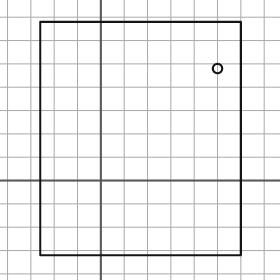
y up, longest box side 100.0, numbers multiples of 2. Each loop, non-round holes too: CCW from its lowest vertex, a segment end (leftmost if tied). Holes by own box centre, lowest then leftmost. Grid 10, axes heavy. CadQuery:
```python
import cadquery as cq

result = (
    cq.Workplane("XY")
    .moveTo(-26.0, -32.0)
    .lineTo(60.0, -32.0)
    .lineTo(60.0, 68.0)
    .lineTo(-26.0, 68.0)
    .close()
    .moveTo(50.0, 48.0)
    .circle(2.0)
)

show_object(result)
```